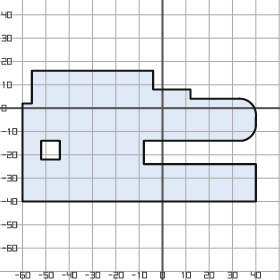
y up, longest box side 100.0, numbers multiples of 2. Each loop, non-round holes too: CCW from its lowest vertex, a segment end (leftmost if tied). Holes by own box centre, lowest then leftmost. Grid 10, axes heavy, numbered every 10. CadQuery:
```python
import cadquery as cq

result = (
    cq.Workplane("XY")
    .moveTo(-60.0, -40.0)
    .lineTo(40.0, -40.0)
    .lineTo(40.0, -24.0)
    .lineTo(-8.0, -24.0)
    .lineTo(-8.0, -14.0)
    .lineTo(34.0, -14.0)
    .threePointArc((38.0, -12.0), (40.0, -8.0))
    .lineTo(40.0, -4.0)
    .threePointArc((38.0, 2.0), (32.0, 4.0))
    .lineTo(12.0, 4.0)
    .lineTo(12.0, 8.0)
    .lineTo(-4.0, 8.0)
    .lineTo(-4.0, 16.0)
    .lineTo(-56.0, 16.0)
    .lineTo(-56.0, 2.0)
    .lineTo(-60.0, 2.0)
    .close()
    .moveTo(-52.0, -22.0)
    .lineTo(-44.0, -22.0)
    .lineTo(-44.0, -14.0)
    .lineTo(-52.0, -14.0)
    .close()
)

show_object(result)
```